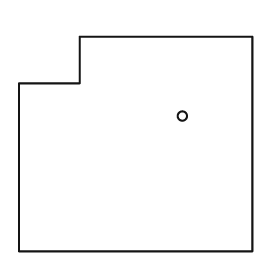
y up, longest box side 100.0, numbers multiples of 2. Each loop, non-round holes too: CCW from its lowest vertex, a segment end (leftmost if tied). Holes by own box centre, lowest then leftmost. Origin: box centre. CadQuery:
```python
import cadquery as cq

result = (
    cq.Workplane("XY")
    .moveTo(-50.0, -46.0)
    .lineTo(50.0, -46.0)
    .lineTo(50.0, 46.0)
    .lineTo(-24.0, 46.0)
    .lineTo(-24.0, 26.0)
    .lineTo(-50.0, 26.0)
    .close()
    .moveTo(20.0, 12.0)
    .circle(2.0)
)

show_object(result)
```